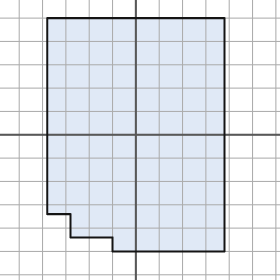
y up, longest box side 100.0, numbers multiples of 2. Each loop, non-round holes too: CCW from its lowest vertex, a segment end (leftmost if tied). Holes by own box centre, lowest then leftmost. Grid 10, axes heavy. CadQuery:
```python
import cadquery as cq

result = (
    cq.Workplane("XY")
    .moveTo(-10.0, -50.0)
    .lineTo(38.0, -50.0)
    .lineTo(38.0, 50.0)
    .lineTo(-38.0, 50.0)
    .lineTo(-38.0, -34.0)
    .lineTo(-28.0, -34.0)
    .lineTo(-28.0, -44.0)
    .lineTo(-10.0, -44.0)
    .close()
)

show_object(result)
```